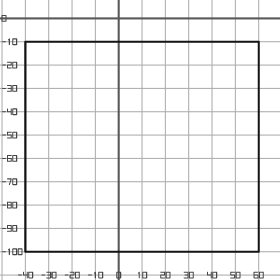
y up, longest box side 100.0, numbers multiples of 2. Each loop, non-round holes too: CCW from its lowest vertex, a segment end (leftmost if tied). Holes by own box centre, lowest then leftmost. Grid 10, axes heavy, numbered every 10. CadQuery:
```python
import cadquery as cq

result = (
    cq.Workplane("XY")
    .moveTo(-40.0, -100.0)
    .lineTo(60.0, -100.0)
    .lineTo(60.0, -10.0)
    .lineTo(-40.0, -10.0)
    .close()
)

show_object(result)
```